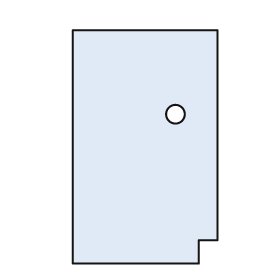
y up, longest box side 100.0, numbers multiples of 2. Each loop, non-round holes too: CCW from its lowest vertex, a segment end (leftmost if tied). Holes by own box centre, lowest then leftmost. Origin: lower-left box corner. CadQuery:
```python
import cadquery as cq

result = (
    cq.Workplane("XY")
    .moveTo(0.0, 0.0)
    .lineTo(54.0, 0.0)
    .lineTo(54.0, 10.0)
    .lineTo(62.0, 10.0)
    .lineTo(62.0, 100.0)
    .lineTo(0.0, 100.0)
    .close()
    .moveTo(44.0, 64.0)
    .circle(4.0)
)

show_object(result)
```